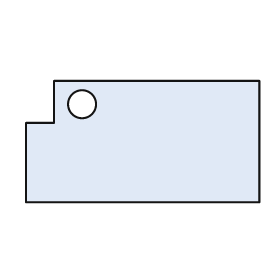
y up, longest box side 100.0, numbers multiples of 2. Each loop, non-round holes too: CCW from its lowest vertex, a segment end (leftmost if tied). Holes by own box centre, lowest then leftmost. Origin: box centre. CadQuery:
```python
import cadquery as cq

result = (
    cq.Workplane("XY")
    .moveTo(-50.0, -26.0)
    .lineTo(50.0, -26.0)
    .lineTo(50.0, 26.0)
    .lineTo(-38.0, 26.0)
    .lineTo(-38.0, 8.0)
    .lineTo(-50.0, 8.0)
    .close()
    .moveTo(-26.0, 16.0)
    .circle(6.0)
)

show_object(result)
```